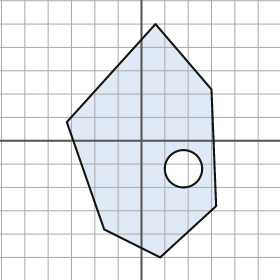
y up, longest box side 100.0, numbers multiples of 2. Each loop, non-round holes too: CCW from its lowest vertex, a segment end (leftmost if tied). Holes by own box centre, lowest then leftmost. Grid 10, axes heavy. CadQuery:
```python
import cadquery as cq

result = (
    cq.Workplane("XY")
    .moveTo(8.0, -50.0)
    .lineTo(32.0, -28.0)
    .lineTo(30.0, 22.0)
    .lineTo(6.0, 50.0)
    .lineTo(-32.0, 8.0)
    .lineTo(-16.0, -38.0)
    .close()
    .moveTo(18.0, -12.0)
    .circle(8.0)
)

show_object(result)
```